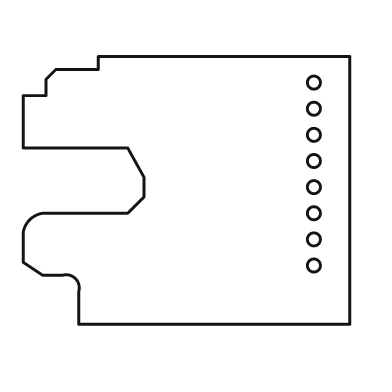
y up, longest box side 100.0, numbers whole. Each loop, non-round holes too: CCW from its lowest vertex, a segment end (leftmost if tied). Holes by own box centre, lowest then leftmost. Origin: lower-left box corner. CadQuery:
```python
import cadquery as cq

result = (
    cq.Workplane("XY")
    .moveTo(17.0, 0.0)
    .lineTo(100.0, 0.0)
    .lineTo(100.0, 82.0)
    .lineTo(23.0, 82.0)
    .lineTo(23.0, 78.0)
    .lineTo(10.0, 78.0)
    .lineTo(7.0, 75.0)
    .lineTo(7.0, 70.0)
    .lineTo(0.0, 70.0)
    .lineTo(0.0, 54.0)
    .lineTo(32.0, 54.0)
    .lineTo(37.0, 45.0)
    .lineTo(37.0, 39.0)
    .lineTo(32.0, 34.0)
    .lineTo(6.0, 34.0)
    .threePointArc((2.0, 32.0), (0.0, 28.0))
    .lineTo(0.0, 19.0)
    .lineTo(6.0, 15.0)
    .lineTo(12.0, 15.0)
    .threePointArc((16.0, 14.0), (17.0, 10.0))
    .close()
    .moveTo(89.0, 18.0)
    .circle(2.0)
    .moveTo(89.0, 26.0)
    .circle(2.0)
    .moveTo(89.0, 34.0)
    .circle(2.0)
    .moveTo(89.0, 42.0)
    .circle(2.0)
    .moveTo(89.0, 50.0)
    .circle(2.0)
    .moveTo(89.0, 58.0)
    .circle(2.0)
    .moveTo(89.0, 66.0)
    .circle(2.0)
    .moveTo(89.0, 74.0)
    .circle(2.0)
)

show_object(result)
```